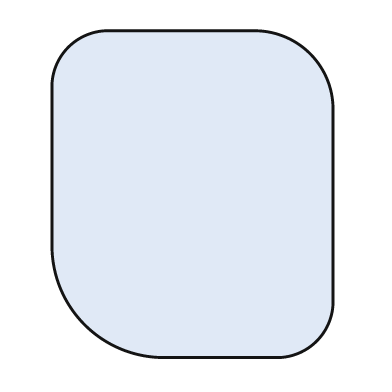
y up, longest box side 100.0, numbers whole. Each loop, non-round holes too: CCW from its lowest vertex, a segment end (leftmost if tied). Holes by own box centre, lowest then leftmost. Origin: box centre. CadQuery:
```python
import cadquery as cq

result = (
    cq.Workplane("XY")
    .moveTo(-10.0, -50.0)
    .lineTo(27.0, -50.0)
    .threePointArc((38.0, -45.0), (43.0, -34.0))
    .lineTo(43.0, 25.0)
    .threePointArc((36.0, 43.0), (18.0, 50.0))
    .lineTo(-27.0, 50.0)
    .threePointArc((-38.0, 45.0), (-43.0, 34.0))
    .lineTo(-43.0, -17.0)
    .threePointArc((-33.0, -40.0), (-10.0, -50.0))
    .close()
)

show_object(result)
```